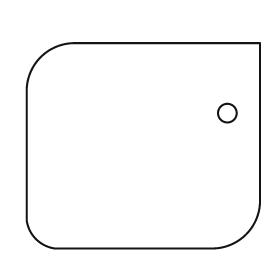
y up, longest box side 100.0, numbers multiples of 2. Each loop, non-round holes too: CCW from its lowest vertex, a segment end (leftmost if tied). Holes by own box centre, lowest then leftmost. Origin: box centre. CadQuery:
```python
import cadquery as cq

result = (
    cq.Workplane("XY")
    .moveTo(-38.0, -44.0)
    .lineTo(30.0, -44.0)
    .threePointArc((44.0, -38.0), (50.0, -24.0))
    .lineTo(50.0, 44.0)
    .lineTo(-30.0, 44.0)
    .threePointArc((-44.0, 38.0), (-50.0, 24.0))
    .lineTo(-50.0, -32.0)
    .threePointArc((-46.0, -40.0), (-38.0, -44.0))
    .close()
    .moveTo(36.0, 14.0)
    .circle(4.0)
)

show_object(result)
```